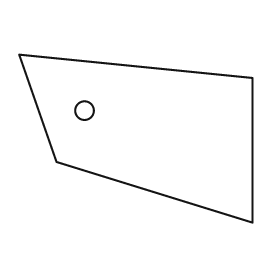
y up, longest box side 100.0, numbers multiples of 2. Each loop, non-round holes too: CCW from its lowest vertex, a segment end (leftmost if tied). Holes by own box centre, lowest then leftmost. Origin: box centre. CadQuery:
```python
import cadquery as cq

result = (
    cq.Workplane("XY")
    .moveTo(50.0, -36.0)
    .lineTo(50.0, 26.0)
    .lineTo(-50.0, 36.0)
    .lineTo(-34.0, -10.0)
    .close()
    .moveTo(-22.0, 12.0)
    .circle(4.0)
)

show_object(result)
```